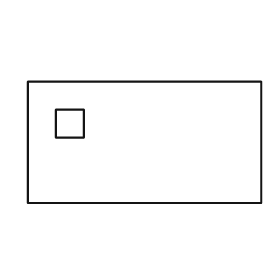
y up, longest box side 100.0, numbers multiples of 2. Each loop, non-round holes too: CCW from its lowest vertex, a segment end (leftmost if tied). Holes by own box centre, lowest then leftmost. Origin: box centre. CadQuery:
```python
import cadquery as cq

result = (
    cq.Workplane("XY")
    .moveTo(-50.0, -26.0)
    .lineTo(50.0, -26.0)
    .lineTo(50.0, 26.0)
    .lineTo(-50.0, 26.0)
    .close()
    .moveTo(-38.0, 2.0)
    .lineTo(-26.0, 2.0)
    .lineTo(-26.0, 14.0)
    .lineTo(-38.0, 14.0)
    .close()
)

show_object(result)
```